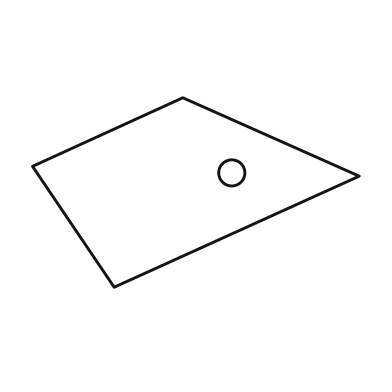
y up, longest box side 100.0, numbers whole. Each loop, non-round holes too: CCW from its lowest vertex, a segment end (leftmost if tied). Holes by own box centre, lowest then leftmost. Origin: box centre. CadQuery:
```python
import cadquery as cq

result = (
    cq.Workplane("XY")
    .moveTo(-25.0, -29.0)
    .lineTo(50.0, 5.0)
    .lineTo(-4.0, 29.0)
    .lineTo(-50.0, 8.0)
    .close()
    .moveTo(11.0, 6.0)
    .circle(4.0)
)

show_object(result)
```